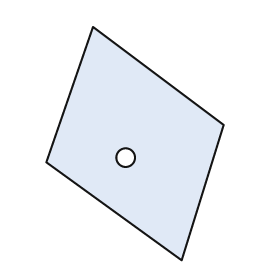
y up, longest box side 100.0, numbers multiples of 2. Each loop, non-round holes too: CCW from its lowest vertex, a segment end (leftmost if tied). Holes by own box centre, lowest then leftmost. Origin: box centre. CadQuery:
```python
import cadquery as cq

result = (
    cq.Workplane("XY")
    .moveTo(20.0, -50.0)
    .lineTo(38.0, 8.0)
    .lineTo(-18.0, 50.0)
    .lineTo(-38.0, -8.0)
    .close()
    .moveTo(-4.0, -6.0)
    .circle(4.0)
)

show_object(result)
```